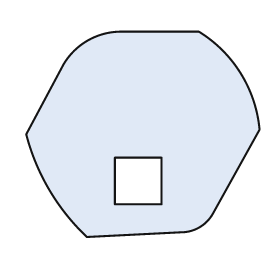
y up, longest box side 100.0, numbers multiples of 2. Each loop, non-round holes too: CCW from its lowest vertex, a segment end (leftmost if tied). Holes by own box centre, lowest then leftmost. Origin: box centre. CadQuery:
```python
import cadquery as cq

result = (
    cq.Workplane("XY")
    .moveTo(-24.0, -44.0)
    .lineTo(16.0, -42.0)
    .threePointArc((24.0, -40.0), (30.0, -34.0))
    .lineTo(50.0, 2.0)
    .threePointArc((42.0, 26.0), (24.0, 44.0))
    .lineTo(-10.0, 44.0)
    .threePointArc((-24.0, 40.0), (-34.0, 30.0))
    .lineTo(-50.0, 0.0)
    .threePointArc((-40.0, -24.0), (-24.0, -44.0))
    .close()
    .moveTo(-12.0, -30.0)
    .lineTo(8.0, -30.0)
    .lineTo(8.0, -10.0)
    .lineTo(-12.0, -10.0)
    .close()
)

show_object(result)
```